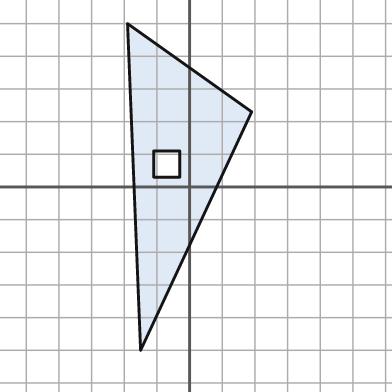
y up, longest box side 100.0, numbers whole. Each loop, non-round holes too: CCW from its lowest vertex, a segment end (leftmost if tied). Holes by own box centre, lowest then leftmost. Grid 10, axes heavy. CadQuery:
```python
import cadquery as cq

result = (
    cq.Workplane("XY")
    .moveTo(-15.0, -50.0)
    .lineTo(19.0, 23.0)
    .lineTo(-19.0, 50.0)
    .close()
    .moveTo(-11.0, 3.0)
    .lineTo(-3.0, 3.0)
    .lineTo(-3.0, 11.0)
    .lineTo(-11.0, 11.0)
    .close()
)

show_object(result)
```